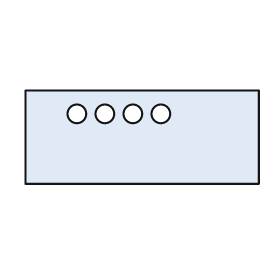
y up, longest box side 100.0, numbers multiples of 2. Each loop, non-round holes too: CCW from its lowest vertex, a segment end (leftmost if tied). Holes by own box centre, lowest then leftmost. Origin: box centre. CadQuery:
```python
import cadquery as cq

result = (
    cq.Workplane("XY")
    .moveTo(-50.0, -20.0)
    .lineTo(50.0, -20.0)
    .lineTo(50.0, 20.0)
    .lineTo(-50.0, 20.0)
    .close()
    .moveTo(-28.0, 10.0)
    .circle(4.0)
    .moveTo(-16.0, 10.0)
    .circle(4.0)
    .moveTo(-4.0, 10.0)
    .circle(4.0)
    .moveTo(8.0, 10.0)
    .circle(4.0)
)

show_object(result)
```